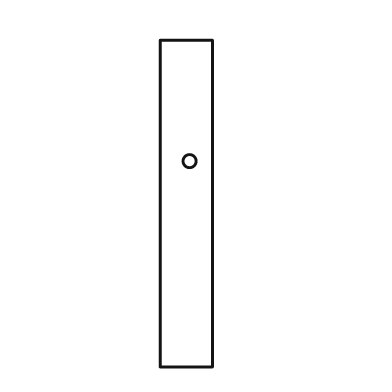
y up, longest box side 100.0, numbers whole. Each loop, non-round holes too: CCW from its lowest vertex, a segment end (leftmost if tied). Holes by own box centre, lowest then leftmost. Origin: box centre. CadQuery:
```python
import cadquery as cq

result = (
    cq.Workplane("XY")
    .moveTo(-8.0, -50.0)
    .lineTo(8.0, -50.0)
    .lineTo(8.0, 50.0)
    .lineTo(-8.0, 50.0)
    .close()
    .moveTo(1.0, 13.0)
    .circle(2.0)
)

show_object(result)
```